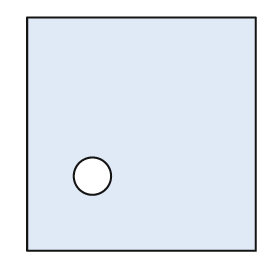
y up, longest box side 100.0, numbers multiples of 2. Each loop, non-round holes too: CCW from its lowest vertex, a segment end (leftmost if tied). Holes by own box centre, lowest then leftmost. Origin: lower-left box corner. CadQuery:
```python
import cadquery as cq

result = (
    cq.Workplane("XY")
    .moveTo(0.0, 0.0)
    .lineTo(98.0, 0.0)
    .lineTo(98.0, 100.0)
    .lineTo(0.0, 100.0)
    .close()
    .moveTo(28.0, 32.0)
    .circle(8.0)
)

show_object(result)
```